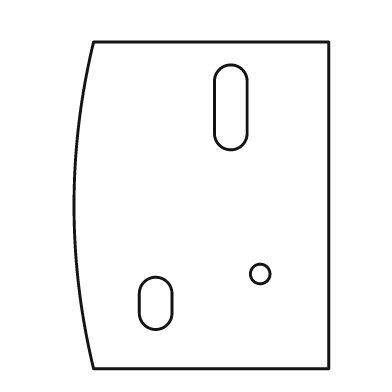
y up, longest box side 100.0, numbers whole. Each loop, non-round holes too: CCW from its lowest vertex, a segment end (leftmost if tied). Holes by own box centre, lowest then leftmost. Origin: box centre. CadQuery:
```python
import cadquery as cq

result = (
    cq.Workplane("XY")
    .moveTo(-33.0, -50.0)
    .lineTo(39.0, -50.0)
    .lineTo(39.0, 50.0)
    .lineTo(-33.0, 50.0)
    .threePointArc((-39.0, 0.0), (-33.0, -50.0))
    .close()
    .moveTo(-19.0, -33.0)
    .threePointArc((-14.0, -38.0), (-9.0, -33.0))
    .lineTo(-9.0, -27.0)
    .threePointArc((-14.0, -22.0), (-19.0, -27.0))
    .close()
    .moveTo(18.0, -21.0)
    .circle(3.0)
    .moveTo(4.0, 22.0)
    .threePointArc((9.0, 17.0), (14.0, 22.0))
    .lineTo(14.0, 38.0)
    .threePointArc((9.0, 43.0), (4.0, 38.0))
    .close()
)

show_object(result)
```